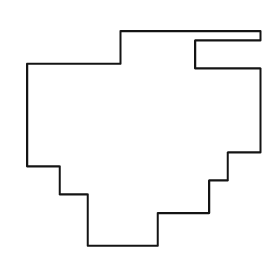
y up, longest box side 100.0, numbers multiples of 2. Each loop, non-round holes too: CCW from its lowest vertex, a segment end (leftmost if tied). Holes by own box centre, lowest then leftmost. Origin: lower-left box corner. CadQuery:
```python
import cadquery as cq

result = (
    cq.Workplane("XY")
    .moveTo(26.0, 0.0)
    .lineTo(56.0, 0.0)
    .lineTo(56.0, 14.0)
    .lineTo(78.0, 14.0)
    .lineTo(78.0, 28.0)
    .lineTo(86.0, 28.0)
    .lineTo(86.0, 40.0)
    .lineTo(100.0, 40.0)
    .lineTo(100.0, 76.0)
    .lineTo(72.0, 76.0)
    .lineTo(72.0, 88.0)
    .lineTo(100.0, 88.0)
    .lineTo(100.0, 92.0)
    .lineTo(40.0, 92.0)
    .lineTo(40.0, 78.0)
    .lineTo(0.0, 78.0)
    .lineTo(0.0, 34.0)
    .lineTo(14.0, 34.0)
    .lineTo(14.0, 22.0)
    .lineTo(26.0, 22.0)
    .close()
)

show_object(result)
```